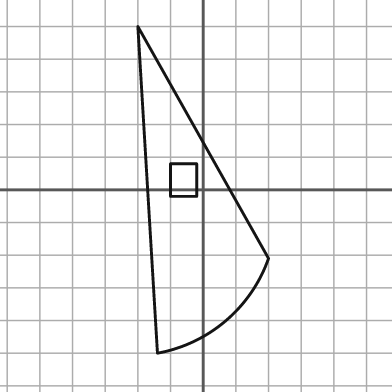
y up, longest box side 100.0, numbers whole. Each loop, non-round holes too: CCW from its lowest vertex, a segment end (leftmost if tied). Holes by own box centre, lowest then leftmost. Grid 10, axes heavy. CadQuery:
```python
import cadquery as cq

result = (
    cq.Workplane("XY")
    .moveTo(-14.0, -50.0)
    .threePointArc((7.0, -40.0), (20.0, -21.0))
    .lineTo(-20.0, 50.0)
    .close()
    .moveTo(-10.0, -2.0)
    .lineTo(-2.0, -2.0)
    .lineTo(-2.0, 8.0)
    .lineTo(-10.0, 8.0)
    .close()
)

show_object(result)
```